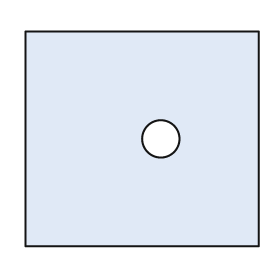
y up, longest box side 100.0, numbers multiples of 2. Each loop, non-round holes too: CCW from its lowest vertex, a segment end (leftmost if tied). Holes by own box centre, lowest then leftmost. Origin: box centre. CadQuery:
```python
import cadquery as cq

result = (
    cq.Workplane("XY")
    .moveTo(-50.0, -46.0)
    .lineTo(50.0, -46.0)
    .lineTo(50.0, 46.0)
    .lineTo(-50.0, 46.0)
    .close()
    .moveTo(8.0, 0.0)
    .circle(8.0)
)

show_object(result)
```